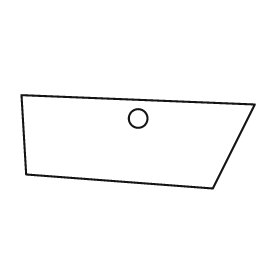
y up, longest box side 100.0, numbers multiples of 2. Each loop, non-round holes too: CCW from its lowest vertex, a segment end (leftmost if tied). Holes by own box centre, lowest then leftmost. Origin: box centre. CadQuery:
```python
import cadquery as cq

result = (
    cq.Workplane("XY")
    .moveTo(32.0, -20.0)
    .lineTo(50.0, 16.0)
    .lineTo(-50.0, 20.0)
    .lineTo(-48.0, -14.0)
    .close()
    .moveTo(0.0, 10.0)
    .circle(4.0)
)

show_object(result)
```